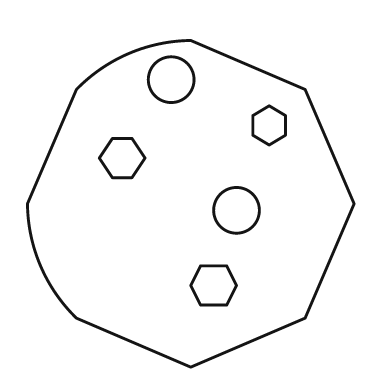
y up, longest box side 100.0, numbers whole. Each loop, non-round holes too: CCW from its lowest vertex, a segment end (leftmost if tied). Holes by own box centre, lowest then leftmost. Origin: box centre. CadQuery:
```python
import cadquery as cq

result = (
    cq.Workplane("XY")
    .moveTo(0.0, -50.0)
    .lineTo(35.0, -35.0)
    .lineTo(50.0, 0.0)
    .lineTo(35.0, 35.0)
    .lineTo(0.0, 50.0)
    .threePointArc((-19.0, 46.0), (-35.0, 35.0))
    .lineTo(-50.0, 0.0)
    .threePointArc((-46.0, -19.0), (-35.0, -35.0))
    .close()
    .moveTo(3.0, -31.0)
    .lineTo(11.0, -31.0)
    .lineTo(14.0, -25.0)
    .lineTo(11.0, -19.0)
    .lineTo(3.0, -19.0)
    .lineTo(0.0, -25.0)
    .close()
    .moveTo(14.0, -2.0)
    .circle(7.0)
    .moveTo(-24.0, 8.0)
    .lineTo(-18.0, 8.0)
    .lineTo(-14.0, 14.0)
    .lineTo(-18.0, 20.0)
    .lineTo(-24.0, 20.0)
    .lineTo(-28.0, 14.0)
    .close()
    .moveTo(24.0, 18.0)
    .lineTo(29.0, 21.0)
    .lineTo(29.0, 27.0)
    .lineTo(24.0, 30.0)
    .lineTo(19.0, 27.0)
    .lineTo(19.0, 21.0)
    .close()
    .moveTo(-6.0, 38.0)
    .circle(7.0)
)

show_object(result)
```